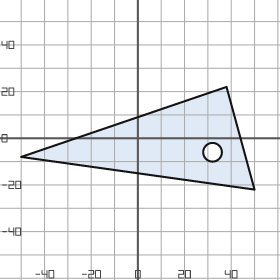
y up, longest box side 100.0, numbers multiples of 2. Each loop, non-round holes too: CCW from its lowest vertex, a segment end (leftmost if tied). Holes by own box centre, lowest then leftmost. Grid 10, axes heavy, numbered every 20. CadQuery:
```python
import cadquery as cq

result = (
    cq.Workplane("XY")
    .moveTo(50.0, -22.0)
    .lineTo(38.0, 22.0)
    .lineTo(-50.0, -8.0)
    .close()
    .moveTo(32.0, -6.0)
    .circle(4.0)
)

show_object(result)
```